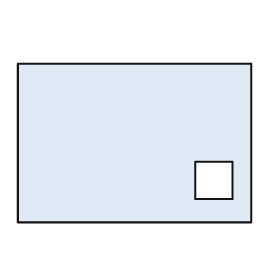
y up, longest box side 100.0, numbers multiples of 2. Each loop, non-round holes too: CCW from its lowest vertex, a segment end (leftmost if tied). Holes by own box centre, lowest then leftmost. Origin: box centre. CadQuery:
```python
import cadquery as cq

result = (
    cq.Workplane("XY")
    .moveTo(-50.0, -34.0)
    .lineTo(50.0, -34.0)
    .lineTo(50.0, 34.0)
    .lineTo(-50.0, 34.0)
    .close()
    .moveTo(26.0, -24.0)
    .lineTo(42.0, -24.0)
    .lineTo(42.0, -8.0)
    .lineTo(26.0, -8.0)
    .close()
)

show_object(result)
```